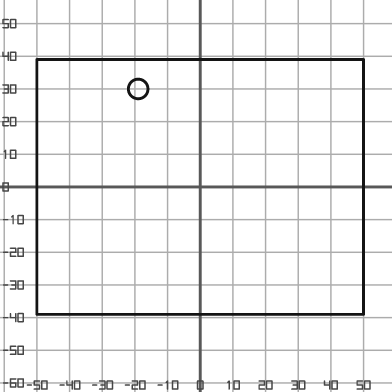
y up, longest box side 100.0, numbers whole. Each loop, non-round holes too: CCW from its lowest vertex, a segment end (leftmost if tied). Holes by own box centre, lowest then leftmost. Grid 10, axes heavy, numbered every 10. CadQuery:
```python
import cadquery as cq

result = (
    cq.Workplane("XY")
    .moveTo(-50.0, -39.0)
    .lineTo(50.0, -39.0)
    .lineTo(50.0, 39.0)
    .lineTo(-50.0, 39.0)
    .close()
    .moveTo(-19.0, 30.0)
    .circle(3.0)
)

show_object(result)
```